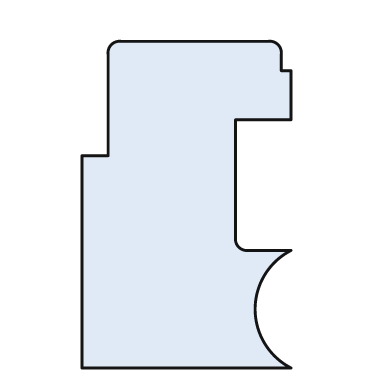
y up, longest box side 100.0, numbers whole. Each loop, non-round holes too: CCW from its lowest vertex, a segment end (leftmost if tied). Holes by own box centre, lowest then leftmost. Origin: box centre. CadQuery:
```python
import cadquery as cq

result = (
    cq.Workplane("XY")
    .moveTo(-32.0, -50.0)
    .lineTo(32.0, -50.0)
    .threePointArc((21.0, -32.0), (32.0, -14.0))
    .lineTo(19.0, -14.0)
    .threePointArc((16.0, -13.0), (15.0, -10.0))
    .lineTo(15.0, 26.0)
    .lineTo(32.0, 26.0)
    .lineTo(32.0, 41.0)
    .lineTo(29.0, 41.0)
    .lineTo(29.0, 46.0)
    .threePointArc((28.0, 49.0), (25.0, 50.0))
    .lineTo(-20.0, 50.0)
    .threePointArc((-23.0, 49.0), (-24.0, 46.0))
    .lineTo(-24.0, 15.0)
    .lineTo(-32.0, 15.0)
    .close()
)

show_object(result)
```